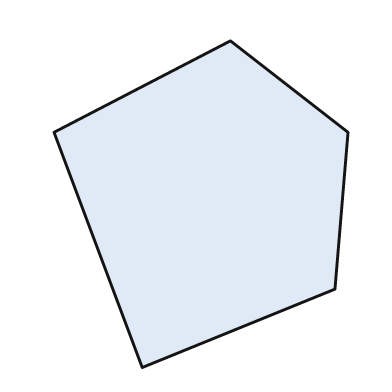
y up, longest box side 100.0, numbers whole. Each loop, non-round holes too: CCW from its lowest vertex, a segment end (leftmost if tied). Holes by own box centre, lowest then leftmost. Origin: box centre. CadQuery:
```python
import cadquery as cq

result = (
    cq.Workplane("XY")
    .moveTo(-18.0, -50.0)
    .lineTo(41.0, -26.0)
    .lineTo(45.0, 22.0)
    .lineTo(9.0, 50.0)
    .lineTo(-45.0, 22.0)
    .close()
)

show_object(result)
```